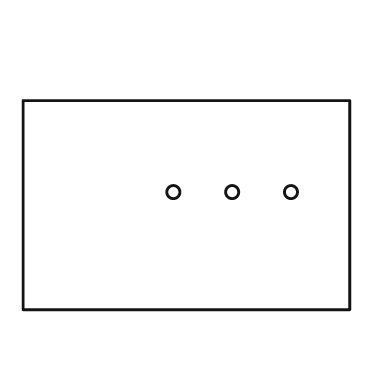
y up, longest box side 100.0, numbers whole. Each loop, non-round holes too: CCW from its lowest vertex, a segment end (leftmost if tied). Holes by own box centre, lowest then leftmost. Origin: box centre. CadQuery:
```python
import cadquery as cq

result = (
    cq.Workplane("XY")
    .moveTo(-50.0, -32.0)
    .lineTo(50.0, -32.0)
    .lineTo(50.0, 32.0)
    .lineTo(-50.0, 32.0)
    .close()
    .moveTo(-4.0, 4.0)
    .circle(2.0)
    .moveTo(14.0, 4.0)
    .circle(2.0)
    .moveTo(32.0, 4.0)
    .circle(2.0)
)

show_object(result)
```